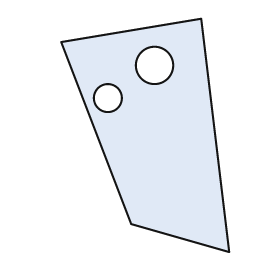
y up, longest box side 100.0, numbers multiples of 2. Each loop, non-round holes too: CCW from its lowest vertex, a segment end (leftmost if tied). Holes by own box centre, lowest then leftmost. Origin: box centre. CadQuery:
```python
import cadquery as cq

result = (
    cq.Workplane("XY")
    .moveTo(36.0, -50.0)
    .lineTo(24.0, 50.0)
    .lineTo(-36.0, 40.0)
    .lineTo(-6.0, -38.0)
    .close()
    .moveTo(-16.0, 16.0)
    .circle(6.0)
    .moveTo(4.0, 30.0)
    .circle(8.0)
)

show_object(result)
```